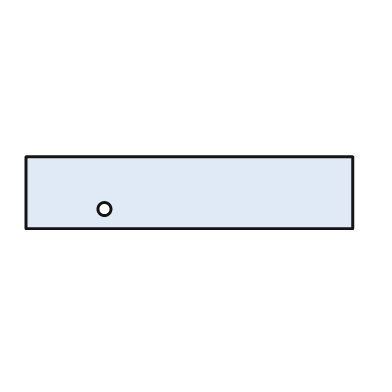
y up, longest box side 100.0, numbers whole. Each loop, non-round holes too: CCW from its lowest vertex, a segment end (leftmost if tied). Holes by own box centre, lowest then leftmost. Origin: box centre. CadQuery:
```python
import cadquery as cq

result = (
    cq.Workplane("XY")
    .moveTo(-50.0, -11.0)
    .lineTo(50.0, -11.0)
    .lineTo(50.0, 11.0)
    .lineTo(-50.0, 11.0)
    .close()
    .moveTo(-26.0, -5.0)
    .circle(2.0)
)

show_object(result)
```